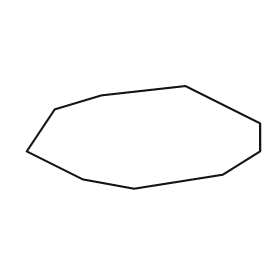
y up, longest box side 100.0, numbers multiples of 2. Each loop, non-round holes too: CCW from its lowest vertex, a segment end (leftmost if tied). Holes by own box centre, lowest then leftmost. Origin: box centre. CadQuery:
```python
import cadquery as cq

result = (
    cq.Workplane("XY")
    .moveTo(-4.0, -22.0)
    .lineTo(34.0, -16.0)
    .lineTo(50.0, -6.0)
    .lineTo(50.0, 6.0)
    .lineTo(18.0, 22.0)
    .lineTo(-18.0, 18.0)
    .lineTo(-38.0, 12.0)
    .lineTo(-50.0, -6.0)
    .lineTo(-26.0, -18.0)
    .close()
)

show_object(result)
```